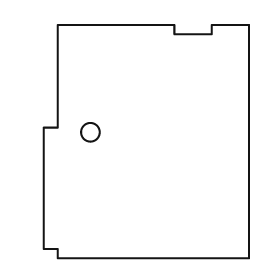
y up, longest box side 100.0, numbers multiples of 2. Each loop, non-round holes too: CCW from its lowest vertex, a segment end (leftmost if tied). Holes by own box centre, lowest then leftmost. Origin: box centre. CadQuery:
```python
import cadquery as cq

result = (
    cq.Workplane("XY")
    .moveTo(-38.0, -50.0)
    .lineTo(44.0, -50.0)
    .lineTo(44.0, 50.0)
    .lineTo(28.0, 50.0)
    .lineTo(28.0, 46.0)
    .lineTo(12.0, 46.0)
    .lineTo(12.0, 50.0)
    .lineTo(-38.0, 50.0)
    .lineTo(-38.0, 6.0)
    .lineTo(-44.0, 6.0)
    .lineTo(-44.0, -46.0)
    .lineTo(-38.0, -46.0)
    .close()
    .moveTo(-24.0, 4.0)
    .circle(4.0)
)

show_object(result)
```